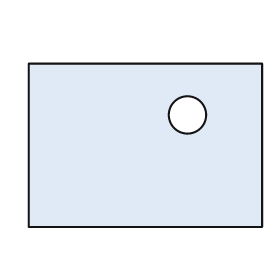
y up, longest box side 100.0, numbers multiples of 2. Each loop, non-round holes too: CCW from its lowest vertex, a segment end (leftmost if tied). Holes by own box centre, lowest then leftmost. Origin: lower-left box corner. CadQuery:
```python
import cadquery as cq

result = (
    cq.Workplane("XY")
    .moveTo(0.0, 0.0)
    .lineTo(100.0, 0.0)
    .lineTo(100.0, 70.0)
    .lineTo(0.0, 70.0)
    .close()
    .moveTo(68.0, 48.0)
    .circle(8.0)
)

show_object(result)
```